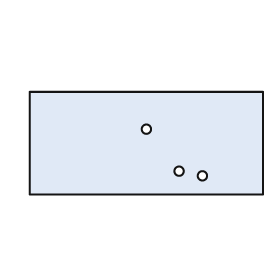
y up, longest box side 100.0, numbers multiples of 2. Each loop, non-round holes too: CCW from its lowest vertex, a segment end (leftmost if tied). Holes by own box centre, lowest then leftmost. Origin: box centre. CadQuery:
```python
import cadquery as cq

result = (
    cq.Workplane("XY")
    .moveTo(-50.0, -22.0)
    .lineTo(50.0, -22.0)
    .lineTo(50.0, 22.0)
    .lineTo(-50.0, 22.0)
    .close()
    .moveTo(24.0, -14.0)
    .circle(2.0)
    .moveTo(14.0, -12.0)
    .circle(2.0)
    .moveTo(0.0, 6.0)
    .circle(2.0)
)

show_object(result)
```